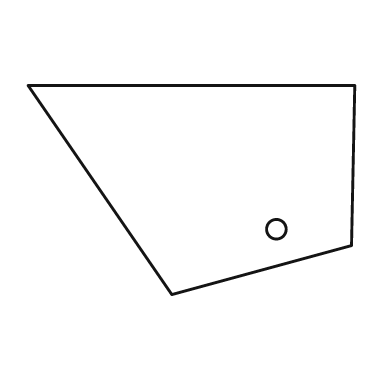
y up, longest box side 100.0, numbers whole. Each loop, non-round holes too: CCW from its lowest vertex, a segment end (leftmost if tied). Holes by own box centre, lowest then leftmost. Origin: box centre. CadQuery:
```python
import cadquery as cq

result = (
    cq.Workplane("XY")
    .moveTo(-6.0, -32.0)
    .lineTo(49.0, -17.0)
    .lineTo(50.0, 32.0)
    .lineTo(-50.0, 32.0)
    .close()
    .moveTo(26.0, -12.0)
    .circle(3.0)
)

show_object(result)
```